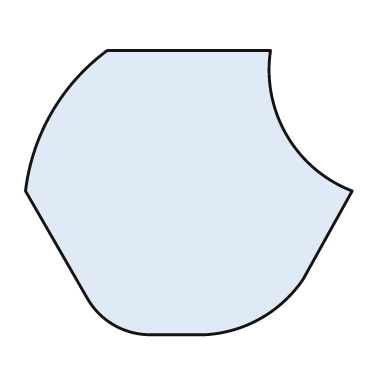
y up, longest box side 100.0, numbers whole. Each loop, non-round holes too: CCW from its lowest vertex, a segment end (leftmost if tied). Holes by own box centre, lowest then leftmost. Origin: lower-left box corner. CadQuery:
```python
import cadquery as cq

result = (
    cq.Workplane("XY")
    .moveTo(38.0, 0.0)
    .lineTo(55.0, 0.0)
    .threePointArc((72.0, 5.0), (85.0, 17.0))
    .lineTo(100.0, 44.0)
    .threePointArc((80.0, 61.0), (75.0, 87.0))
    .lineTo(25.0, 87.0)
    .threePointArc((8.0, 68.0), (0.0, 44.0))
    .lineTo(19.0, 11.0)
    .threePointArc((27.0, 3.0), (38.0, 0.0))
    .close()
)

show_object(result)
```